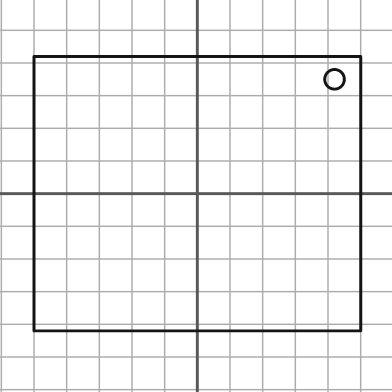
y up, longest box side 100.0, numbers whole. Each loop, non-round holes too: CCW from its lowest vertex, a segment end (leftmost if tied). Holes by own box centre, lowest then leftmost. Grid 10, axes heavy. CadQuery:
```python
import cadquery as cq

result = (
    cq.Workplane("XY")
    .moveTo(-50.0, -42.0)
    .lineTo(50.0, -42.0)
    .lineTo(50.0, 42.0)
    .lineTo(-50.0, 42.0)
    .close()
    .moveTo(42.0, 35.0)
    .circle(3.0)
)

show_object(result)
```